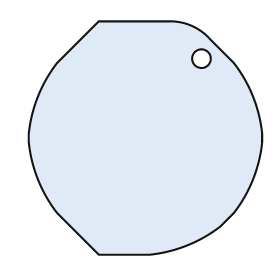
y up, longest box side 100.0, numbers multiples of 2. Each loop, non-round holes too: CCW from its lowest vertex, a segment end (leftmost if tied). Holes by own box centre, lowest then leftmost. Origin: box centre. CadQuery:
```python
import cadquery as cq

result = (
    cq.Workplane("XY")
    .moveTo(-20.0, -50.0)
    .lineTo(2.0, -50.0)
    .threePointArc((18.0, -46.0), (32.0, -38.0))
    .lineTo(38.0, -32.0)
    .threePointArc((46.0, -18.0), (50.0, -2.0))
    .lineTo(50.0, 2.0)
    .threePointArc((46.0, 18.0), (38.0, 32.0))
    .lineTo(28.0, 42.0)
    .threePointArc((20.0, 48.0), (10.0, 50.0))
    .lineTo(-20.0, 50.0)
    .lineTo(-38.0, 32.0)
    .threePointArc((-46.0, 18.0), (-50.0, 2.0))
    .lineTo(-50.0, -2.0)
    .threePointArc((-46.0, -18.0), (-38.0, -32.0))
    .close()
    .moveTo(24.0, 34.0)
    .circle(4.0)
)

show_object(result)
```